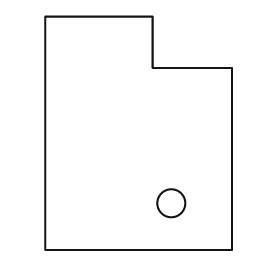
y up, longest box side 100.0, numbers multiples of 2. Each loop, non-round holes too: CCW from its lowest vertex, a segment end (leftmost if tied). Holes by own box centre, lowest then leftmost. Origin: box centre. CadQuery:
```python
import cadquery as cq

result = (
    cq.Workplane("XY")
    .moveTo(-40.0, -50.0)
    .lineTo(40.0, -50.0)
    .lineTo(40.0, 28.0)
    .lineTo(6.0, 28.0)
    .lineTo(6.0, 50.0)
    .lineTo(-40.0, 50.0)
    .close()
    .moveTo(14.0, -30.0)
    .circle(6.0)
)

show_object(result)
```